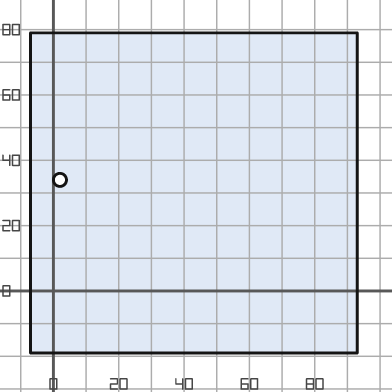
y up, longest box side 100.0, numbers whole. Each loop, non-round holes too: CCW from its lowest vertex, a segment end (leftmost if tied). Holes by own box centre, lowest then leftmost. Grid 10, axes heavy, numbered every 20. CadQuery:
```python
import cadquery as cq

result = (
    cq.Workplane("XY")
    .moveTo(-7.0, -19.0)
    .lineTo(93.0, -19.0)
    .lineTo(93.0, 79.0)
    .lineTo(-7.0, 79.0)
    .close()
    .moveTo(2.0, 34.0)
    .circle(2.0)
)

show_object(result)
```